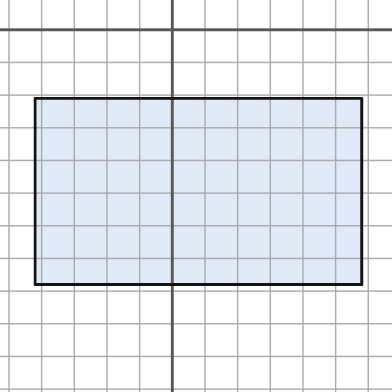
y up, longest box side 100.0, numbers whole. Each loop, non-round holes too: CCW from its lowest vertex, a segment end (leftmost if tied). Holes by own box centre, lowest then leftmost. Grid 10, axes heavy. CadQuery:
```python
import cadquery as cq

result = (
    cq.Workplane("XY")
    .moveTo(-42.0, -78.0)
    .lineTo(58.0, -78.0)
    .lineTo(58.0, -21.0)
    .lineTo(-42.0, -21.0)
    .close()
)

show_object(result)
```